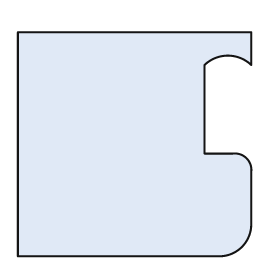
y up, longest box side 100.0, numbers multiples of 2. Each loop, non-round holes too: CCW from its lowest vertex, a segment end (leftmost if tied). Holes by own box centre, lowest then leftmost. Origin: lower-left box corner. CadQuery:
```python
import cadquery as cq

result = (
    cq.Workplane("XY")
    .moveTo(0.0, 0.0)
    .lineTo(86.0, 0.0)
    .threePointArc((96.0, 4.0), (100.0, 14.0))
    .lineTo(100.0, 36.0)
    .threePointArc((98.0, 42.0), (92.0, 44.0))
    .lineTo(80.0, 44.0)
    .lineTo(80.0, 82.0)
    .threePointArc((90.0, 86.0), (100.0, 82.0))
    .lineTo(100.0, 96.0)
    .lineTo(0.0, 96.0)
    .close()
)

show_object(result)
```